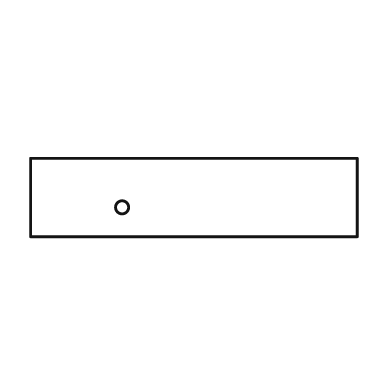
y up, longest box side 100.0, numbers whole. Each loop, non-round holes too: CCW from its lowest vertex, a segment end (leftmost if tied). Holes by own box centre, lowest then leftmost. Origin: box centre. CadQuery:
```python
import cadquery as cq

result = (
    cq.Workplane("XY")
    .moveTo(-50.0, -12.0)
    .lineTo(50.0, -12.0)
    .lineTo(50.0, 12.0)
    .lineTo(-50.0, 12.0)
    .close()
    .moveTo(-22.0, -3.0)
    .circle(2.0)
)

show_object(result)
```